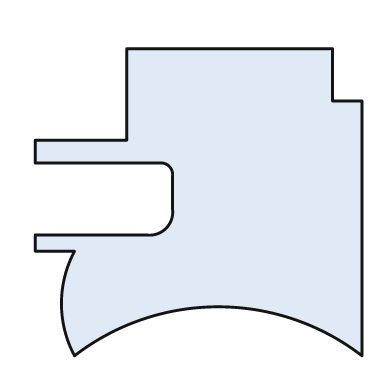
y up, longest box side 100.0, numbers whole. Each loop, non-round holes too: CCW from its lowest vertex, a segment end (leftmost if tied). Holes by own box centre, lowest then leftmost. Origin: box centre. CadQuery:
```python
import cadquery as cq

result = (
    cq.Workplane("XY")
    .moveTo(-38.0, -47.0)
    .threePointArc((6.0, -32.0), (50.0, -47.0))
    .lineTo(50.0, 31.0)
    .lineTo(41.0, 31.0)
    .lineTo(41.0, 47.0)
    .lineTo(-22.0, 47.0)
    .lineTo(-22.0, 19.0)
    .lineTo(-50.0, 19.0)
    .lineTo(-50.0, 12.0)
    .lineTo(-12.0, 12.0)
    .threePointArc((-9.0, 11.0), (-8.0, 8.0))
    .lineTo(-8.0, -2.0)
    .threePointArc((-10.0, -8.0), (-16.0, -10.0))
    .lineTo(-50.0, -10.0)
    .lineTo(-50.0, -15.0)
    .lineTo(-38.0, -15.0)
    .threePointArc((-42.0, -31.0), (-38.0, -47.0))
    .close()
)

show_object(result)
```